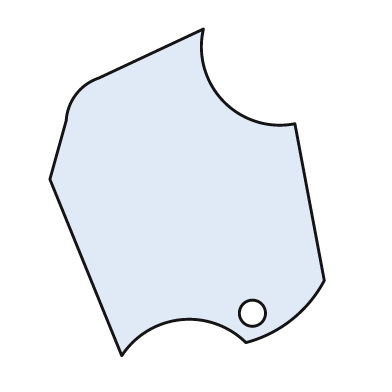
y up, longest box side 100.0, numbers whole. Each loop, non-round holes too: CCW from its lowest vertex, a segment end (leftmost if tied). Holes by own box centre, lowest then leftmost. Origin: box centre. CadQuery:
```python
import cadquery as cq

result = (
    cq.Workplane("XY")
    .moveTo(-20.0, -50.0)
    .threePointArc((-2.0, -39.0), (18.0, -46.0))
    .threePointArc((32.0, -39.0), (42.0, -27.0))
    .lineTo(33.0, 21.0)
    .threePointArc((11.0, 28.0), (5.0, 50.0))
    .lineTo(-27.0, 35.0)
    .threePointArc((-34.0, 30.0), (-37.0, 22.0))
    .lineTo(-42.0, 4.0)
    .close()
    .moveTo(20.0, -37.0)
    .circle(4.0)
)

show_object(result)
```